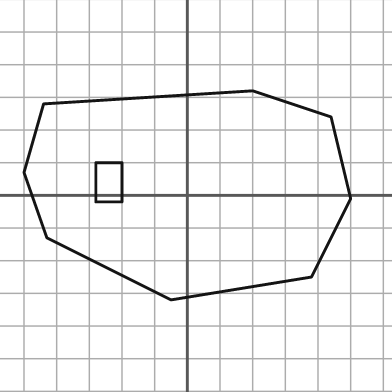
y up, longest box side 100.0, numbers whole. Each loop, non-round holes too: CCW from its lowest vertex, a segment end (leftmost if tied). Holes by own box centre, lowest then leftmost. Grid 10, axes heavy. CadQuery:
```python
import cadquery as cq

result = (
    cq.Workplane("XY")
    .moveTo(-5.0, -32.0)
    .lineTo(38.0, -25.0)
    .lineTo(50.0, -1.0)
    .lineTo(44.0, 24.0)
    .lineTo(20.0, 32.0)
    .lineTo(-44.0, 28.0)
    .lineTo(-50.0, 7.0)
    .lineTo(-43.0, -13.0)
    .close()
    .moveTo(-28.0, -2.0)
    .lineTo(-20.0, -2.0)
    .lineTo(-20.0, 10.0)
    .lineTo(-28.0, 10.0)
    .close()
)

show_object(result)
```